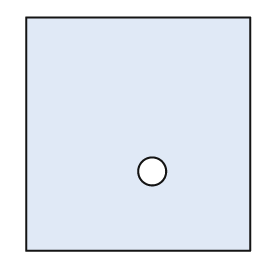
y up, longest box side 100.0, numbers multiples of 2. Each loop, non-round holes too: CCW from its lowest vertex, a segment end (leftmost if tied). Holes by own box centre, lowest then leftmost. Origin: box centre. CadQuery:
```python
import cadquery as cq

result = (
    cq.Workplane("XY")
    .moveTo(-48.0, -50.0)
    .lineTo(48.0, -50.0)
    .lineTo(48.0, 50.0)
    .lineTo(-48.0, 50.0)
    .close()
    .moveTo(6.0, -16.0)
    .circle(6.0)
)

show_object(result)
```